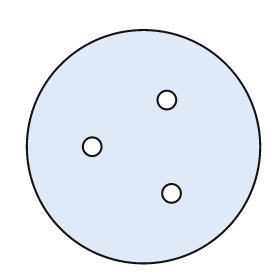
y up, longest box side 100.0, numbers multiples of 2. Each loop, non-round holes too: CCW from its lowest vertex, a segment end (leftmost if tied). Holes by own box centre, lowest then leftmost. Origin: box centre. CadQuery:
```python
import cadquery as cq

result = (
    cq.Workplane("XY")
    .moveTo(0.0, 0.0)
    .circle(50.0)
    .moveTo(12.0, -20.0)
    .circle(4.0)
    .moveTo(-22.0, 0.0)
    .circle(4.0)
    .moveTo(10.0, 20.0)
    .circle(4.0)
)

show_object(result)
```